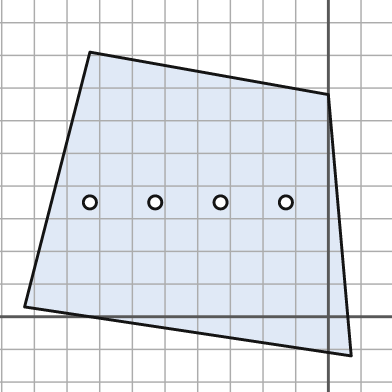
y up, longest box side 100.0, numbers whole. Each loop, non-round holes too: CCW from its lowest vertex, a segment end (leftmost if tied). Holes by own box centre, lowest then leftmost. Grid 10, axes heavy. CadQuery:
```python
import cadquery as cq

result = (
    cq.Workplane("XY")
    .moveTo(7.0, -12.0)
    .lineTo(0.0, 68.0)
    .lineTo(-73.0, 81.0)
    .lineTo(-93.0, 3.0)
    .close()
    .moveTo(-73.0, 35.0)
    .circle(2.0)
    .moveTo(-53.0, 35.0)
    .circle(2.0)
    .moveTo(-33.0, 35.0)
    .circle(2.0)
    .moveTo(-13.0, 35.0)
    .circle(2.0)
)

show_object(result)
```